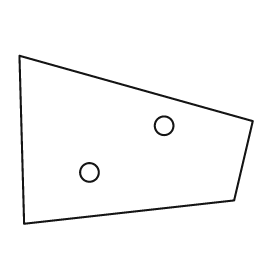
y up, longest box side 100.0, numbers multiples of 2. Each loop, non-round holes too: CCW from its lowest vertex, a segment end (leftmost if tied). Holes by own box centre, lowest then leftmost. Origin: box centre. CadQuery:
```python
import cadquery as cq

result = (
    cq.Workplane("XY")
    .moveTo(-48.0, -36.0)
    .lineTo(42.0, -26.0)
    .lineTo(50.0, 8.0)
    .lineTo(-50.0, 36.0)
    .close()
    .moveTo(-20.0, -14.0)
    .circle(4.0)
    .moveTo(12.0, 6.0)
    .circle(4.0)
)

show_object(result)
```